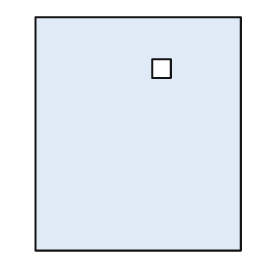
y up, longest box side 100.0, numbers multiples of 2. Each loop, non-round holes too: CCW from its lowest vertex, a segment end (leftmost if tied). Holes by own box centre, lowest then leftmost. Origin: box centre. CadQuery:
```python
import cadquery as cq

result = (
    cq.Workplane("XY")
    .moveTo(-44.0, -50.0)
    .lineTo(44.0, -50.0)
    .lineTo(44.0, 50.0)
    .lineTo(-44.0, 50.0)
    .close()
    .moveTo(6.0, 24.0)
    .lineTo(14.0, 24.0)
    .lineTo(14.0, 32.0)
    .lineTo(6.0, 32.0)
    .close()
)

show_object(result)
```